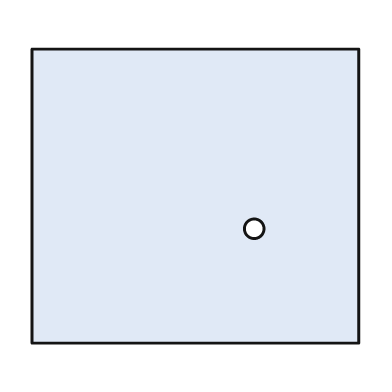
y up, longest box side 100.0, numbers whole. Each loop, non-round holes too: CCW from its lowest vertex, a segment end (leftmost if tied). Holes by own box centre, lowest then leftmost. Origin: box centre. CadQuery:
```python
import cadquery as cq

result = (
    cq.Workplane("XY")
    .moveTo(-50.0, -45.0)
    .lineTo(50.0, -45.0)
    .lineTo(50.0, 45.0)
    .lineTo(-50.0, 45.0)
    .close()
    .moveTo(18.0, -10.0)
    .circle(3.0)
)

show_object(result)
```